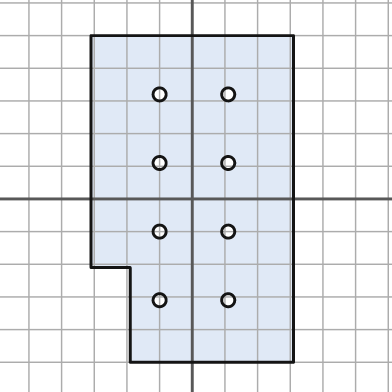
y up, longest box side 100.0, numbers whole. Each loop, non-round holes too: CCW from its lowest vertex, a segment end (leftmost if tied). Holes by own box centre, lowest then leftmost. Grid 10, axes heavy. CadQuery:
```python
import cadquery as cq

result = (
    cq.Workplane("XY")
    .moveTo(-19.0, -50.0)
    .lineTo(31.0, -50.0)
    .lineTo(31.0, 50.0)
    .lineTo(-31.0, 50.0)
    .lineTo(-31.0, -21.0)
    .lineTo(-19.0, -21.0)
    .close()
    .moveTo(-10.0, -31.0)
    .circle(2.0)
    .moveTo(11.0, -31.0)
    .circle(2.0)
    .moveTo(-10.0, -10.0)
    .circle(2.0)
    .moveTo(11.0, -10.0)
    .circle(2.0)
    .moveTo(-10.0, 11.0)
    .circle(2.0)
    .moveTo(11.0, 11.0)
    .circle(2.0)
    .moveTo(-10.0, 32.0)
    .circle(2.0)
    .moveTo(11.0, 32.0)
    .circle(2.0)
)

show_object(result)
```